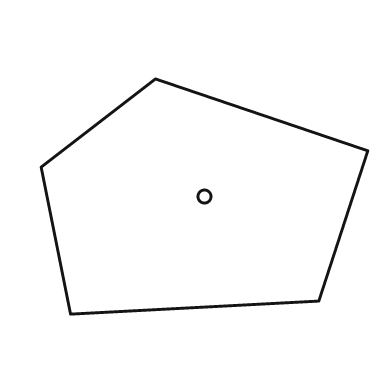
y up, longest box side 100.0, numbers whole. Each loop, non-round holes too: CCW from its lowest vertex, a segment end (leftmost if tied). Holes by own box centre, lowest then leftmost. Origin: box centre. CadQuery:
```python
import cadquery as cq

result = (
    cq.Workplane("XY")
    .moveTo(-41.0, -36.0)
    .lineTo(35.0, -32.0)
    .lineTo(50.0, 14.0)
    .lineTo(-15.0, 36.0)
    .lineTo(-50.0, 9.0)
    .close()
    .moveTo(0.0, 0.0)
    .circle(2.0)
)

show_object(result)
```